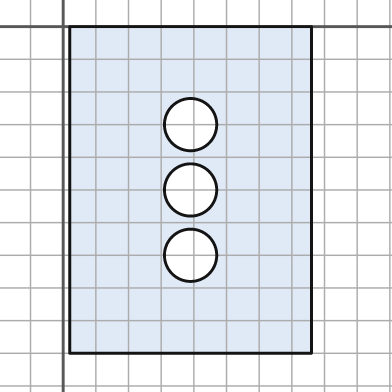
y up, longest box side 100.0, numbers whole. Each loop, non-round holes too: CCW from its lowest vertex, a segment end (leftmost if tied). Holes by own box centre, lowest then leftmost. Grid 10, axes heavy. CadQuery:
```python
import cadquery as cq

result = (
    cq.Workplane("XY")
    .moveTo(2.0, -100.0)
    .lineTo(76.0, -100.0)
    .lineTo(76.0, 0.0)
    .lineTo(2.0, 0.0)
    .close()
    .moveTo(39.0, -70.0)
    .circle(8.0)
    .moveTo(39.0, -50.0)
    .circle(8.0)
    .moveTo(39.0, -30.0)
    .circle(8.0)
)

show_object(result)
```